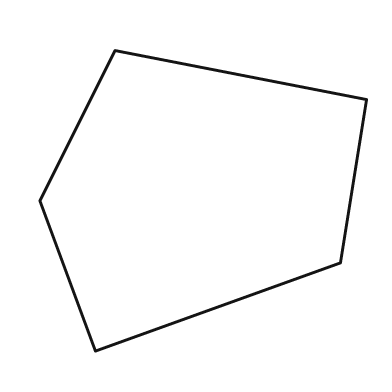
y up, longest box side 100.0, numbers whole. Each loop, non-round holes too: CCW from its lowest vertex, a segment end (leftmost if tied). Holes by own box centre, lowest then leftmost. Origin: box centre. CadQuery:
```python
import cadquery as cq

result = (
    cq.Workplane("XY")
    .moveTo(-33.0, -46.0)
    .lineTo(42.0, -19.0)
    .lineTo(50.0, 31.0)
    .lineTo(-27.0, 46.0)
    .lineTo(-50.0, 0.0)
    .close()
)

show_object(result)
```